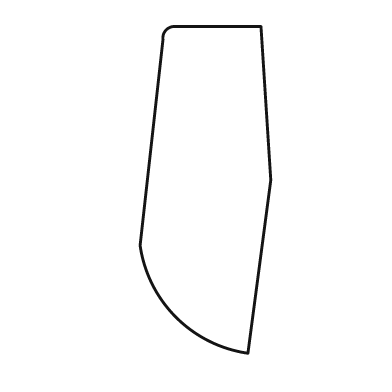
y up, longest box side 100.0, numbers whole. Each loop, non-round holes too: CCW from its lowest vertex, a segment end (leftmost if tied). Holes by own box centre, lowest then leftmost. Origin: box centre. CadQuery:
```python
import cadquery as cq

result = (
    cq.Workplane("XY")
    .moveTo(13.0, -50.0)
    .lineTo(20.0, 3.0)
    .lineTo(17.0, 50.0)
    .lineTo(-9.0, 50.0)
    .threePointArc((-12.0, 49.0), (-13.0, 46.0))
    .lineTo(-20.0, -17.0)
    .threePointArc((-9.0, -39.0), (13.0, -50.0))
    .close()
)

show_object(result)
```